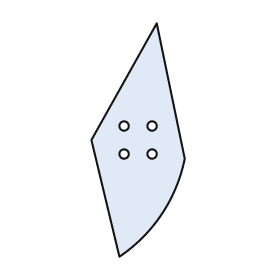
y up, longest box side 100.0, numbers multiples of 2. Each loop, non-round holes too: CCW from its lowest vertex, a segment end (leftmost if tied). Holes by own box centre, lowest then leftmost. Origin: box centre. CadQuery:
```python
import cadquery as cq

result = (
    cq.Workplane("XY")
    .moveTo(-8.0, -50.0)
    .threePointArc((10.0, -32.0), (20.0, -8.0))
    .lineTo(8.0, 50.0)
    .lineTo(-20.0, 0.0)
    .close()
    .moveTo(-6.0, -6.0)
    .circle(2.0)
    .moveTo(6.0, -6.0)
    .circle(2.0)
    .moveTo(-6.0, 6.0)
    .circle(2.0)
    .moveTo(6.0, 6.0)
    .circle(2.0)
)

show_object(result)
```